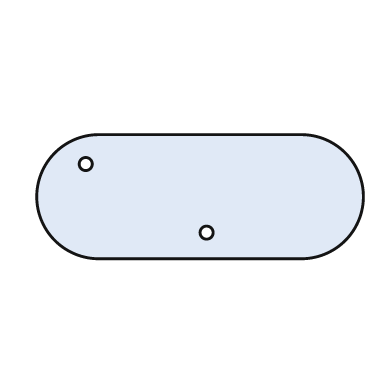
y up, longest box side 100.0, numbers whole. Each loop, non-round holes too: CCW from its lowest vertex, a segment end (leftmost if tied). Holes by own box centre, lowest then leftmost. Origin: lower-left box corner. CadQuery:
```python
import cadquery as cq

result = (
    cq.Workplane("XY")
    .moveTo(19.0, 0.0)
    .lineTo(81.0, 0.0)
    .threePointArc((100.0, 19.0), (81.0, 38.0))
    .lineTo(19.0, 38.0)
    .threePointArc((0.0, 19.0), (19.0, 0.0))
    .close()
    .moveTo(52.0, 8.0)
    .circle(2.0)
    .moveTo(15.0, 29.0)
    .circle(2.0)
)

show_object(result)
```